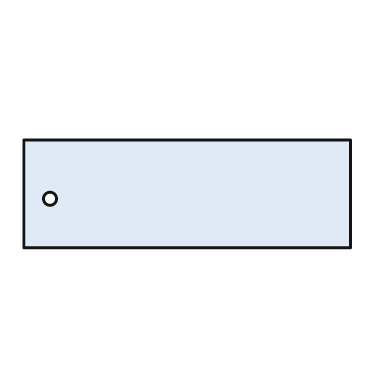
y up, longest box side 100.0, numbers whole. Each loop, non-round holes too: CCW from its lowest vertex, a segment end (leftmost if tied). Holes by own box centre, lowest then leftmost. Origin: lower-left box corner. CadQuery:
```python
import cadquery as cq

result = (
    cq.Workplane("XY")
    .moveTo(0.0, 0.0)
    .lineTo(100.0, 0.0)
    .lineTo(100.0, 33.0)
    .lineTo(0.0, 33.0)
    .close()
    .moveTo(8.0, 15.0)
    .circle(2.0)
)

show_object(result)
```